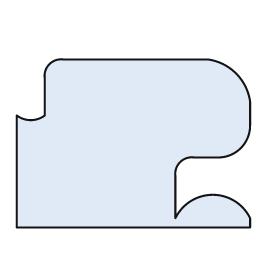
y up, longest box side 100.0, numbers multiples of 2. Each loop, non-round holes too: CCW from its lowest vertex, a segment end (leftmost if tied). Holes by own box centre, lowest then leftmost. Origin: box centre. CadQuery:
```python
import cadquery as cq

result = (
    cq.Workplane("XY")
    .moveTo(-50.0, -36.0)
    .lineTo(50.0, -36.0)
    .lineTo(50.0, -32.0)
    .threePointArc((34.0, -22.0), (18.0, -32.0))
    .lineTo(18.0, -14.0)
    .threePointArc((20.0, -8.0), (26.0, -6.0))
    .lineTo(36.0, -6.0)
    .threePointArc((46.0, -2.0), (50.0, 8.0))
    .lineTo(50.0, 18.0)
    .threePointArc((44.0, 30.0), (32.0, 36.0))
    .lineTo(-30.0, 36.0)
    .threePointArc((-36.0, 34.0), (-38.0, 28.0))
    .lineTo(-38.0, 12.0)
    .threePointArc((-44.0, 10.0), (-50.0, 12.0))
    .close()
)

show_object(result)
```